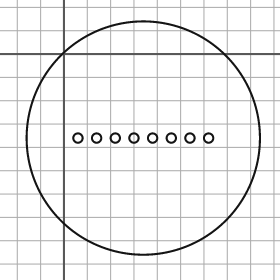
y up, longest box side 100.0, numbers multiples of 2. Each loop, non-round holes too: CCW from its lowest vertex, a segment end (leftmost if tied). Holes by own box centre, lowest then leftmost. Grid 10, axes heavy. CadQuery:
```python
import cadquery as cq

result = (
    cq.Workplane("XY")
    .moveTo(34.0, -36.0)
    .circle(50.0)
    .moveTo(6.0, -36.0)
    .circle(2.0)
    .moveTo(14.0, -36.0)
    .circle(2.0)
    .moveTo(22.0, -36.0)
    .circle(2.0)
    .moveTo(30.0, -36.0)
    .circle(2.0)
    .moveTo(38.0, -36.0)
    .circle(2.0)
    .moveTo(46.0, -36.0)
    .circle(2.0)
    .moveTo(54.0, -36.0)
    .circle(2.0)
    .moveTo(62.0, -36.0)
    .circle(2.0)
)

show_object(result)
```